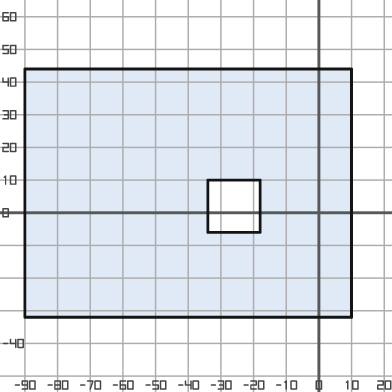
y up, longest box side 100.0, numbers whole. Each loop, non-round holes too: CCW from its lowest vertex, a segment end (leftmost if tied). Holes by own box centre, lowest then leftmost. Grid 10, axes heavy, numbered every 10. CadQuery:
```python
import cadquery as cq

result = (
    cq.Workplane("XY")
    .moveTo(-90.0, -32.0)
    .lineTo(10.0, -32.0)
    .lineTo(10.0, 44.0)
    .lineTo(-90.0, 44.0)
    .close()
    .moveTo(-34.0, -6.0)
    .lineTo(-18.0, -6.0)
    .lineTo(-18.0, 10.0)
    .lineTo(-34.0, 10.0)
    .close()
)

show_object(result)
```